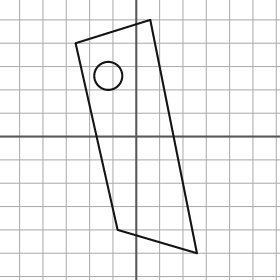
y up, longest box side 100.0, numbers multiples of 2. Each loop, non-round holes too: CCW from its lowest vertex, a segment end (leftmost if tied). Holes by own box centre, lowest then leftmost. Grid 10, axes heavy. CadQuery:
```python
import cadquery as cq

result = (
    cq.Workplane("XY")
    .moveTo(26.0, -50.0)
    .lineTo(6.0, 50.0)
    .lineTo(-26.0, 40.0)
    .lineTo(-8.0, -40.0)
    .close()
    .moveTo(-12.0, 26.0)
    .circle(6.0)
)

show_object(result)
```